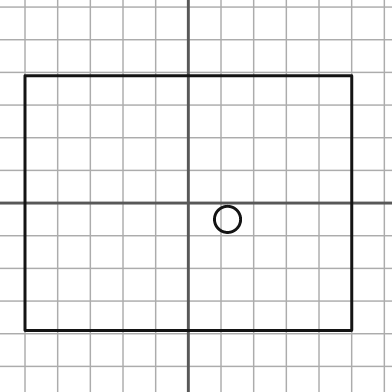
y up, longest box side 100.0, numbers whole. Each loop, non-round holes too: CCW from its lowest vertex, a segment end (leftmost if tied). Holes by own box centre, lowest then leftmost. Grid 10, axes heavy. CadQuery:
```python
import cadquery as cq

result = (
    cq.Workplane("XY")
    .moveTo(-50.0, -39.0)
    .lineTo(50.0, -39.0)
    .lineTo(50.0, 39.0)
    .lineTo(-50.0, 39.0)
    .close()
    .moveTo(12.0, -5.0)
    .circle(4.0)
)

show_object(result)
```